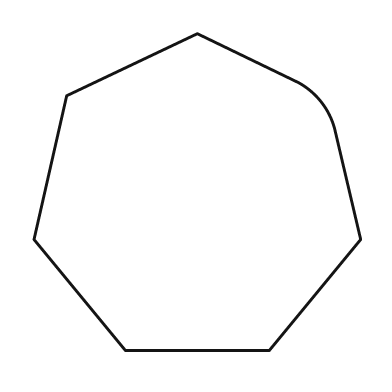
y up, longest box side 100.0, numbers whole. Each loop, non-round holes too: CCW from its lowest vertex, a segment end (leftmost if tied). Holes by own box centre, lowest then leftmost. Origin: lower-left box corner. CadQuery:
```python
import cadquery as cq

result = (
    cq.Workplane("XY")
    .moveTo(28.0, 0.0)
    .lineTo(72.0, 0.0)
    .lineTo(100.0, 34.0)
    .lineTo(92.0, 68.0)
    .threePointArc((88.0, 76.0), (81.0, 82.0))
    .lineTo(50.0, 97.0)
    .lineTo(10.0, 78.0)
    .lineTo(0.0, 34.0)
    .close()
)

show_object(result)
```